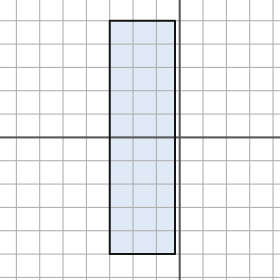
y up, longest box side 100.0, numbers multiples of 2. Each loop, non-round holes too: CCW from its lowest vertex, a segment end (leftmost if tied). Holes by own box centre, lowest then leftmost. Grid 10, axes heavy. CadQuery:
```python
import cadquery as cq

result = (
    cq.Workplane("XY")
    .moveTo(-30.0, -50.0)
    .lineTo(-2.0, -50.0)
    .lineTo(-2.0, 50.0)
    .lineTo(-30.0, 50.0)
    .close()
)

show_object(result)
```